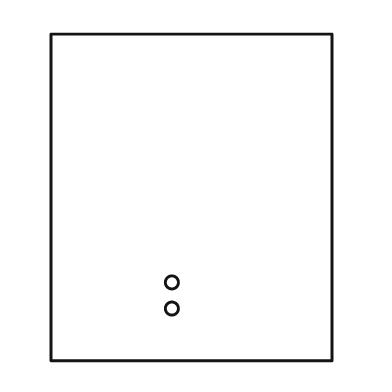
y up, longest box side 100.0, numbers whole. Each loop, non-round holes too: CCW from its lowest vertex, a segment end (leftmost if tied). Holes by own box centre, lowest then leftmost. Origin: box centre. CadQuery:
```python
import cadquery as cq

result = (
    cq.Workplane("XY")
    .moveTo(-43.0, -50.0)
    .lineTo(43.0, -50.0)
    .lineTo(43.0, 50.0)
    .lineTo(-43.0, 50.0)
    .close()
    .moveTo(-6.0, -34.0)
    .circle(2.0)
    .moveTo(-6.0, -26.0)
    .circle(2.0)
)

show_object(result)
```